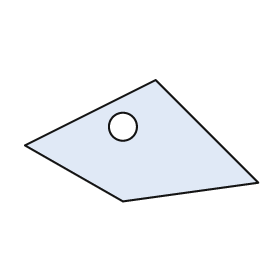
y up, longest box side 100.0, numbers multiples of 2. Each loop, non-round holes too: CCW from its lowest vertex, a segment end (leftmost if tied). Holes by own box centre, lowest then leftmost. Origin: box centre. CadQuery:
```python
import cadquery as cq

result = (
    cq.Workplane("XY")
    .moveTo(-8.0, -26.0)
    .lineTo(50.0, -18.0)
    .lineTo(6.0, 26.0)
    .lineTo(-50.0, -2.0)
    .close()
    .moveTo(-8.0, 6.0)
    .circle(6.0)
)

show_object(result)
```